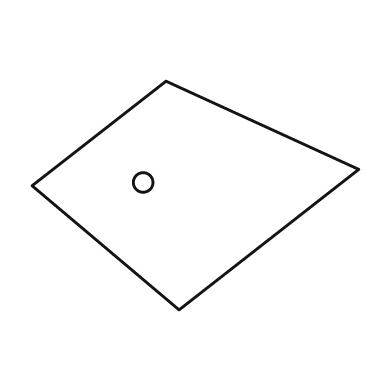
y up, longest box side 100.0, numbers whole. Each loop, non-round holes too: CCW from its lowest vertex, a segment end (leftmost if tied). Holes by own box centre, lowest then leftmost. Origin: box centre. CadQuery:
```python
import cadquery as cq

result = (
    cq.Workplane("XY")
    .moveTo(-5.0, -35.0)
    .lineTo(50.0, 8.0)
    .lineTo(-9.0, 35.0)
    .lineTo(-50.0, 3.0)
    .close()
    .moveTo(-16.0, 4.0)
    .circle(3.0)
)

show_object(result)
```